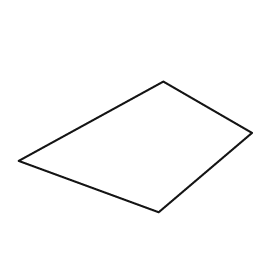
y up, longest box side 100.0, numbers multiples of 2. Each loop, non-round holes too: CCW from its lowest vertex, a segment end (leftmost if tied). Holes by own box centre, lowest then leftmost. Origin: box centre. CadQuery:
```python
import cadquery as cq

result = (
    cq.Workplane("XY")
    .moveTo(10.0, -28.0)
    .lineTo(50.0, 6.0)
    .lineTo(12.0, 28.0)
    .lineTo(-50.0, -6.0)
    .close()
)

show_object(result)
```